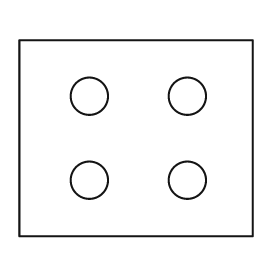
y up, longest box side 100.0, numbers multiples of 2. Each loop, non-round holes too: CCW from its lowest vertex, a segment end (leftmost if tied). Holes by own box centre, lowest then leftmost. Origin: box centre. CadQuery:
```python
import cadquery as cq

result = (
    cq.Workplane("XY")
    .moveTo(-50.0, -42.0)
    .lineTo(50.0, -42.0)
    .lineTo(50.0, 42.0)
    .lineTo(-50.0, 42.0)
    .close()
    .moveTo(-20.0, -18.0)
    .circle(8.0)
    .moveTo(22.0, -18.0)
    .circle(8.0)
    .moveTo(-20.0, 18.0)
    .circle(8.0)
    .moveTo(22.0, 18.0)
    .circle(8.0)
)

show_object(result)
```